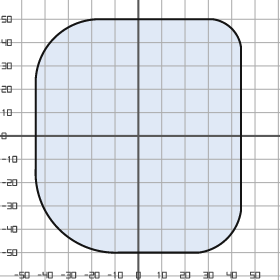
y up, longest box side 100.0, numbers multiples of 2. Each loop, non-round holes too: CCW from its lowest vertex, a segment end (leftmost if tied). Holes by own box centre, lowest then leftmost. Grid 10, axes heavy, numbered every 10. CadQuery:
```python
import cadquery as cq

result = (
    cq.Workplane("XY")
    .moveTo(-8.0, -50.0)
    .lineTo(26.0, -50.0)
    .threePointArc((38.0, -44.0), (44.0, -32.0))
    .lineTo(44.0, 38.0)
    .threePointArc((40.0, 46.0), (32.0, 50.0))
    .lineTo(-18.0, 50.0)
    .threePointArc((-36.0, 42.0), (-44.0, 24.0))
    .lineTo(-44.0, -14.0)
    .threePointArc((-34.0, -40.0), (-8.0, -50.0))
    .close()
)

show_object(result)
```